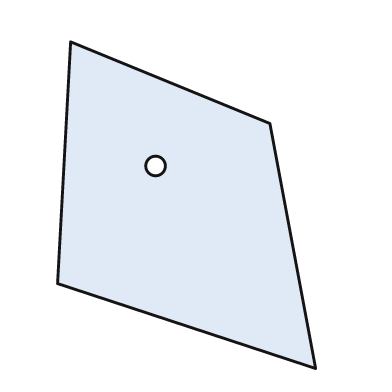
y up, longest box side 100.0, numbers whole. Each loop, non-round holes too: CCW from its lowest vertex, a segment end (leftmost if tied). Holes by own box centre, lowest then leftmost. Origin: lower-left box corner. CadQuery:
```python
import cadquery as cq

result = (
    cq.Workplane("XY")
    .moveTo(79.0, 0.0)
    .lineTo(65.0, 75.0)
    .lineTo(4.0, 100.0)
    .lineTo(0.0, 26.0)
    .close()
    .moveTo(30.0, 62.0)
    .circle(3.0)
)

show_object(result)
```